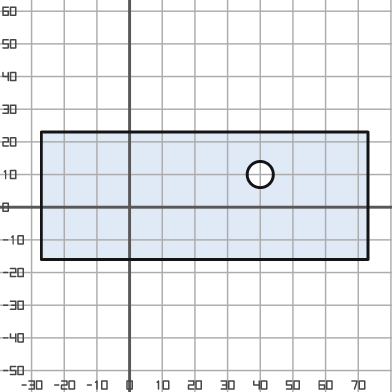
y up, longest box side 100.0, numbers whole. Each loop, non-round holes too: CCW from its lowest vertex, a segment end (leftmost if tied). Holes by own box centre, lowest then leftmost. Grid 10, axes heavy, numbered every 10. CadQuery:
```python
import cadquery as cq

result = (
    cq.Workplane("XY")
    .moveTo(-27.0, -16.0)
    .lineTo(73.0, -16.0)
    .lineTo(73.0, 23.0)
    .lineTo(-27.0, 23.0)
    .close()
    .moveTo(40.0, 10.0)
    .circle(4.0)
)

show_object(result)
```